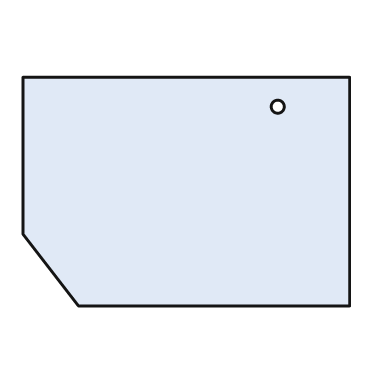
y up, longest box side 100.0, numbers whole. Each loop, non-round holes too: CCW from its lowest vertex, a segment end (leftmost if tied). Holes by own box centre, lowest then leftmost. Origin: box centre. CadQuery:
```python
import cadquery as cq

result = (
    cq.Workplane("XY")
    .moveTo(-33.0, -35.0)
    .lineTo(50.0, -35.0)
    .lineTo(50.0, 35.0)
    .lineTo(-50.0, 35.0)
    .lineTo(-50.0, -13.0)
    .close()
    .moveTo(28.0, 26.0)
    .circle(2.0)
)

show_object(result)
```